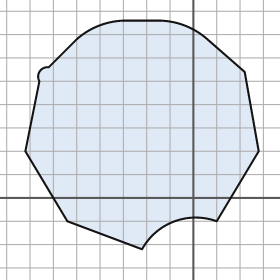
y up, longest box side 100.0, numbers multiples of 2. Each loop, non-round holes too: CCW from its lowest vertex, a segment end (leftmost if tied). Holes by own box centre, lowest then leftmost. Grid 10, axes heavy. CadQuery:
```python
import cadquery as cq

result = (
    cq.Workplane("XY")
    .moveTo(-22.0, -22.0)
    .threePointArc((-8.0, -10.0), (10.0, -10.0))
    .lineTo(28.0, 20.0)
    .lineTo(22.0, 54.0)
    .lineTo(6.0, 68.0)
    .threePointArc((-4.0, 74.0), (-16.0, 76.0))
    .lineTo(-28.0, 76.0)
    .threePointArc((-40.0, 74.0), (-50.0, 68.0))
    .lineTo(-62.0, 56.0)
    .threePointArc((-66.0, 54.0), (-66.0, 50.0))
    .lineTo(-72.0, 20.0)
    .lineTo(-54.0, -10.0)
    .close()
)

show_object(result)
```